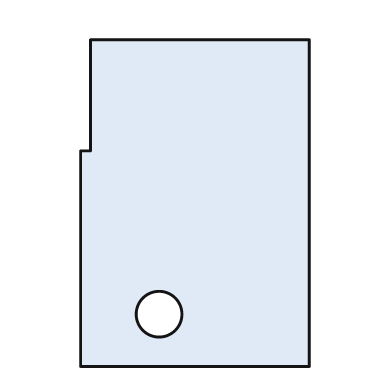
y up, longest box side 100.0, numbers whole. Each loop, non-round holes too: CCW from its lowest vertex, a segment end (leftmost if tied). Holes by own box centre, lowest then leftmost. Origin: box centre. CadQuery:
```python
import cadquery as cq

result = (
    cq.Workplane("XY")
    .moveTo(-35.0, -50.0)
    .lineTo(35.0, -50.0)
    .lineTo(35.0, 50.0)
    .lineTo(-32.0, 50.0)
    .lineTo(-32.0, 16.0)
    .lineTo(-35.0, 16.0)
    .close()
    .moveTo(-11.0, -34.0)
    .circle(7.0)
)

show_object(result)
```